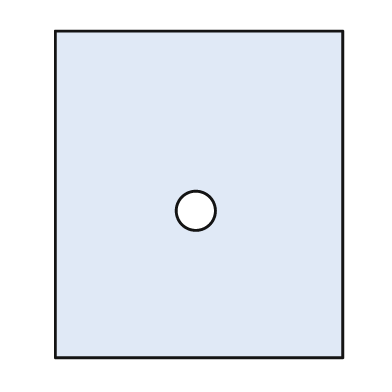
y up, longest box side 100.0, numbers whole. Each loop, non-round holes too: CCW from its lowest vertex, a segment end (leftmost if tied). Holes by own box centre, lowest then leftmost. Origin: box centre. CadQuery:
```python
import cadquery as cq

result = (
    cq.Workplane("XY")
    .moveTo(-44.0, -50.0)
    .lineTo(44.0, -50.0)
    .lineTo(44.0, 50.0)
    .lineTo(-44.0, 50.0)
    .close()
    .moveTo(-1.0, -5.0)
    .circle(6.0)
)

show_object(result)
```